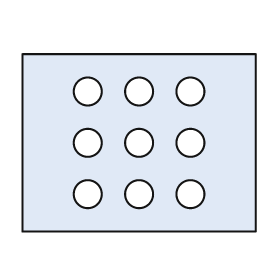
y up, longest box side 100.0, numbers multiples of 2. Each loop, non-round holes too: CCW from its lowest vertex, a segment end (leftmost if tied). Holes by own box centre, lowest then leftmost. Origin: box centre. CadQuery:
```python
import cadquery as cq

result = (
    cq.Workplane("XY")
    .moveTo(-50.0, -38.0)
    .lineTo(50.0, -38.0)
    .lineTo(50.0, 38.0)
    .lineTo(-50.0, 38.0)
    .close()
    .moveTo(-22.0, -22.0)
    .circle(6.0)
    .moveTo(0.0, -22.0)
    .circle(6.0)
    .moveTo(22.0, -22.0)
    .circle(6.0)
    .moveTo(-22.0, 0.0)
    .circle(6.0)
    .moveTo(0.0, 0.0)
    .circle(6.0)
    .moveTo(22.0, 0.0)
    .circle(6.0)
    .moveTo(-22.0, 22.0)
    .circle(6.0)
    .moveTo(0.0, 22.0)
    .circle(6.0)
    .moveTo(22.0, 22.0)
    .circle(6.0)
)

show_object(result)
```